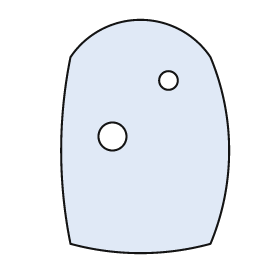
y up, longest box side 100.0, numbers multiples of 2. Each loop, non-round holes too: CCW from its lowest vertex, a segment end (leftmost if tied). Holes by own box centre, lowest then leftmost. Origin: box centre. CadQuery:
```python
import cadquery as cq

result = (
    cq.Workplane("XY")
    .moveTo(-32.0, -46.0)
    .threePointArc((-2.0, -50.0), (28.0, -46.0))
    .threePointArc((36.0, -6.0), (28.0, 34.0))
    .threePointArc((-2.0, 50.0), (-32.0, 34.0))
    .threePointArc((-36.0, -6.0), (-32.0, -46.0))
    .close()
    .moveTo(-14.0, 0.0)
    .circle(6.0)
    .moveTo(10.0, 24.0)
    .circle(4.0)
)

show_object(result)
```